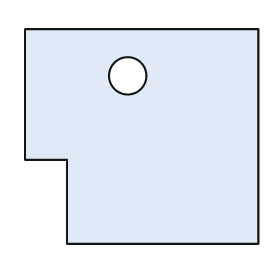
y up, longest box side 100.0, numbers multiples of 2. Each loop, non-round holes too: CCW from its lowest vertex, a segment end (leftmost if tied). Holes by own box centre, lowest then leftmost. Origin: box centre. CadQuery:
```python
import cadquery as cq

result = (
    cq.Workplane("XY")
    .moveTo(-32.0, -46.0)
    .lineTo(50.0, -46.0)
    .lineTo(50.0, 46.0)
    .lineTo(-50.0, 46.0)
    .lineTo(-50.0, -10.0)
    .lineTo(-32.0, -10.0)
    .close()
    .moveTo(-6.0, 26.0)
    .circle(8.0)
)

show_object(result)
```